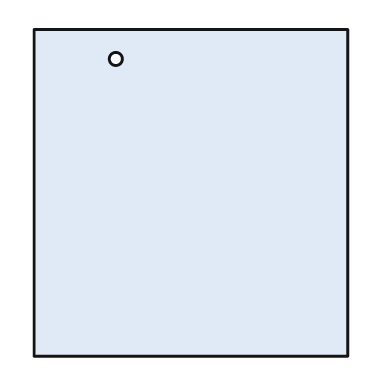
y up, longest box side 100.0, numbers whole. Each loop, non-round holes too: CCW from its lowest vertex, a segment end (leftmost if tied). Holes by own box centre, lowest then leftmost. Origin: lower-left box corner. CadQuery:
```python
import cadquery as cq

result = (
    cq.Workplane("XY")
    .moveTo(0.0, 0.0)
    .lineTo(96.0, 0.0)
    .lineTo(96.0, 100.0)
    .lineTo(0.0, 100.0)
    .close()
    .moveTo(25.0, 91.0)
    .circle(2.0)
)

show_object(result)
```